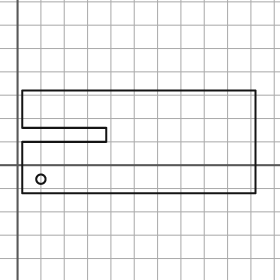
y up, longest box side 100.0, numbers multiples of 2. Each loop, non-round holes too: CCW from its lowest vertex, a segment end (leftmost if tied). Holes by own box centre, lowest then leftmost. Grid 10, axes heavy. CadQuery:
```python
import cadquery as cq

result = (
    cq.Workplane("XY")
    .moveTo(2.0, -12.0)
    .lineTo(102.0, -12.0)
    .lineTo(102.0, 32.0)
    .lineTo(2.0, 32.0)
    .lineTo(2.0, 16.0)
    .lineTo(38.0, 16.0)
    .lineTo(38.0, 10.0)
    .lineTo(2.0, 10.0)
    .close()
    .moveTo(10.0, -6.0)
    .circle(2.0)
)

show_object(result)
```